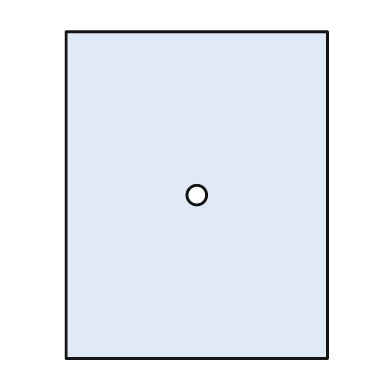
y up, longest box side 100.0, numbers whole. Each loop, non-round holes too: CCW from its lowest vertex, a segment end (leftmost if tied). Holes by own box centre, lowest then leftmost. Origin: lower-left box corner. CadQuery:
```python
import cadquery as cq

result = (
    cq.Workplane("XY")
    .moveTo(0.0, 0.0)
    .lineTo(80.0, 0.0)
    .lineTo(80.0, 100.0)
    .lineTo(0.0, 100.0)
    .close()
    .moveTo(40.0, 50.0)
    .circle(3.0)
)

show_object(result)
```